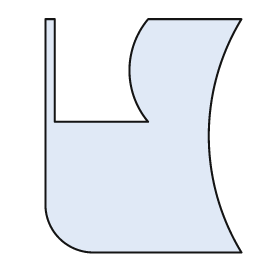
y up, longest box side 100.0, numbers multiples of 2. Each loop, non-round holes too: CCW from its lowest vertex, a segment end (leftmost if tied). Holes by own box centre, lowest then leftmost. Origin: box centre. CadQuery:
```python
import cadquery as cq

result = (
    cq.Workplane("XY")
    .moveTo(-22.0, -50.0)
    .lineTo(42.0, -50.0)
    .threePointArc((28.0, 0.0), (42.0, 50.0))
    .lineTo(2.0, 50.0)
    .threePointArc((-6.0, 28.0), (2.0, 6.0))
    .lineTo(-38.0, 6.0)
    .lineTo(-38.0, 50.0)
    .lineTo(-42.0, 50.0)
    .lineTo(-42.0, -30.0)
    .threePointArc((-36.0, -44.0), (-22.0, -50.0))
    .close()
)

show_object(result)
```